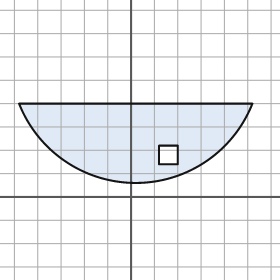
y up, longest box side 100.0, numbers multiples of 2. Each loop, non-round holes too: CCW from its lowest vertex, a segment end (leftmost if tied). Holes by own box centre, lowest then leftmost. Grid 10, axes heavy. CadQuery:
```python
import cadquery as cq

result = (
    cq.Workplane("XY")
    .moveTo(-48.0, 40.0)
    .threePointArc((2.0, 6.0), (52.0, 40.0))
    .close()
    .moveTo(12.0, 14.0)
    .lineTo(20.0, 14.0)
    .lineTo(20.0, 22.0)
    .lineTo(12.0, 22.0)
    .close()
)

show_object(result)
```